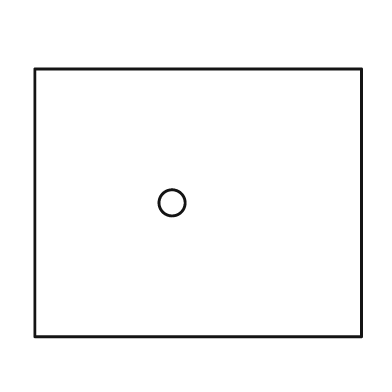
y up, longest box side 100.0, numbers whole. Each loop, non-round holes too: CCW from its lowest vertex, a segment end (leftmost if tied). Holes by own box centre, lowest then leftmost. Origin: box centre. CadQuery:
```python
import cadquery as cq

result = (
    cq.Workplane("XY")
    .moveTo(-50.0, -41.0)
    .lineTo(50.0, -41.0)
    .lineTo(50.0, 41.0)
    .lineTo(-50.0, 41.0)
    .close()
    .moveTo(-8.0, 0.0)
    .circle(4.0)
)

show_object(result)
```